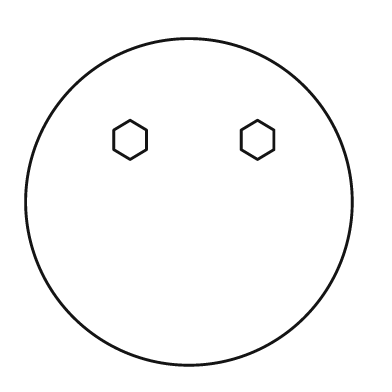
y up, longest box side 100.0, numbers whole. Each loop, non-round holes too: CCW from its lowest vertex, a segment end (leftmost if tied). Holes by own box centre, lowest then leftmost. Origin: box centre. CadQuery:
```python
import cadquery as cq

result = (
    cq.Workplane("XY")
    .moveTo(0.0, 0.0)
    .circle(50.0)
    .moveTo(-18.0, 13.0)
    .lineTo(-13.0, 16.0)
    .lineTo(-13.0, 22.0)
    .lineTo(-18.0, 25.0)
    .lineTo(-23.0, 22.0)
    .lineTo(-23.0, 16.0)
    .close()
    .moveTo(21.0, 13.0)
    .lineTo(26.0, 16.0)
    .lineTo(26.0, 22.0)
    .lineTo(21.0, 25.0)
    .lineTo(16.0, 22.0)
    .lineTo(16.0, 16.0)
    .close()
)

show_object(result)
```